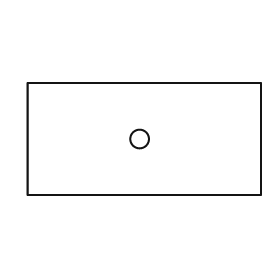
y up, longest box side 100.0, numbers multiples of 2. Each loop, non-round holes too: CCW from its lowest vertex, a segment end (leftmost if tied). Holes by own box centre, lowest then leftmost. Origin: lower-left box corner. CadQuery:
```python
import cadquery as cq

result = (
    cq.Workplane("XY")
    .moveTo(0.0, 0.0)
    .lineTo(100.0, 0.0)
    .lineTo(100.0, 48.0)
    .lineTo(0.0, 48.0)
    .close()
    .moveTo(48.0, 24.0)
    .circle(4.0)
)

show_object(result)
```